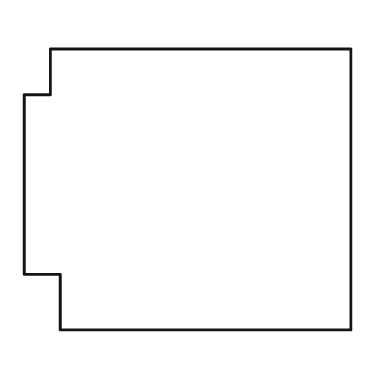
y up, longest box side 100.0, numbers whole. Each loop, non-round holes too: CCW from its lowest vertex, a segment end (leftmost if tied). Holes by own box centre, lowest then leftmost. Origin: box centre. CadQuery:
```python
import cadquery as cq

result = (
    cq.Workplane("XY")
    .moveTo(-39.0, -43.0)
    .lineTo(50.0, -43.0)
    .lineTo(50.0, 43.0)
    .lineTo(-42.0, 43.0)
    .lineTo(-42.0, 29.0)
    .lineTo(-50.0, 29.0)
    .lineTo(-50.0, -26.0)
    .lineTo(-39.0, -26.0)
    .close()
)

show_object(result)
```